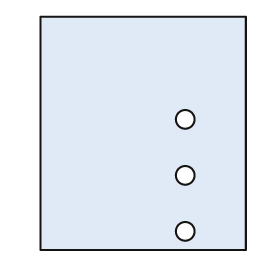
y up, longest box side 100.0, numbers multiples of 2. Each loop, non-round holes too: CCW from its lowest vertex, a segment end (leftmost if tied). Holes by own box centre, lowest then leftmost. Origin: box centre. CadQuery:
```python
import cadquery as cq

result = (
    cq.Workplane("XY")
    .moveTo(-44.0, -50.0)
    .lineTo(44.0, -50.0)
    .lineTo(44.0, 50.0)
    .lineTo(-44.0, 50.0)
    .close()
    .moveTo(18.0, -42.0)
    .circle(4.0)
    .moveTo(18.0, -18.0)
    .circle(4.0)
    .moveTo(18.0, 6.0)
    .circle(4.0)
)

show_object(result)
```